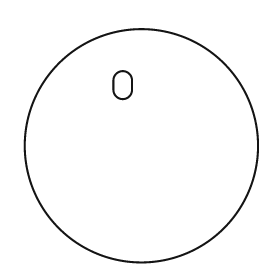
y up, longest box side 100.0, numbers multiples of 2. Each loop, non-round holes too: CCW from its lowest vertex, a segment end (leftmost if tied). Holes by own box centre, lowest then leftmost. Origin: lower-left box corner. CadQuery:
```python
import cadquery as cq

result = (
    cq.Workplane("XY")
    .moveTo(50.0, 50.0)
    .circle(50.0)
    .moveTo(38.0, 74.0)
    .threePointArc((42.0, 70.0), (46.0, 74.0))
    .lineTo(46.0, 78.0)
    .threePointArc((42.0, 82.0), (38.0, 78.0))
    .close()
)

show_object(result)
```